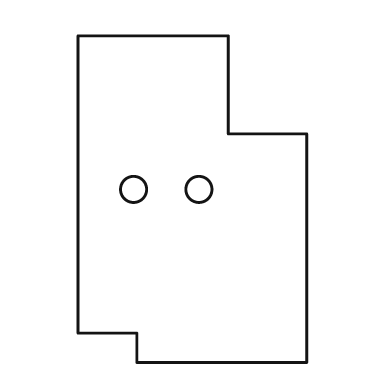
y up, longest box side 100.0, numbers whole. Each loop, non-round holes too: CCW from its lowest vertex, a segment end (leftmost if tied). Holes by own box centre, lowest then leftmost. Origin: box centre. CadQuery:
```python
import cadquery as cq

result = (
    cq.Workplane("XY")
    .moveTo(-17.0, -50.0)
    .lineTo(35.0, -50.0)
    .lineTo(35.0, 20.0)
    .lineTo(11.0, 20.0)
    .lineTo(11.0, 50.0)
    .lineTo(-35.0, 50.0)
    .lineTo(-35.0, -41.0)
    .lineTo(-17.0, -41.0)
    .close()
    .moveTo(-18.0, 3.0)
    .circle(4.0)
    .moveTo(2.0, 3.0)
    .circle(4.0)
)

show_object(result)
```